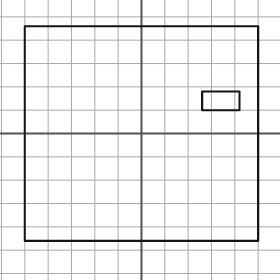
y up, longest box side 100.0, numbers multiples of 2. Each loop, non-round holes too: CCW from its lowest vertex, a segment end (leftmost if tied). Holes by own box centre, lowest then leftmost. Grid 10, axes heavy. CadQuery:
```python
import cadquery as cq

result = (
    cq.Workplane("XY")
    .moveTo(-50.0, -46.0)
    .lineTo(50.0, -46.0)
    .lineTo(50.0, 46.0)
    .lineTo(-50.0, 46.0)
    .close()
    .moveTo(26.0, 10.0)
    .lineTo(42.0, 10.0)
    .lineTo(42.0, 18.0)
    .lineTo(26.0, 18.0)
    .close()
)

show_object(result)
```